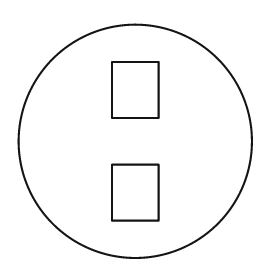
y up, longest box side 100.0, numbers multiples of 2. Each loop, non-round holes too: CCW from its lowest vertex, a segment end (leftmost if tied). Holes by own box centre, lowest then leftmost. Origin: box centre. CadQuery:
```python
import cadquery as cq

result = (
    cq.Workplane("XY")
    .moveTo(0.0, 0.0)
    .circle(50.0)
    .moveTo(-10.0, -34.0)
    .lineTo(10.0, -34.0)
    .lineTo(10.0, -10.0)
    .lineTo(-10.0, -10.0)
    .close()
    .moveTo(-10.0, 10.0)
    .lineTo(10.0, 10.0)
    .lineTo(10.0, 34.0)
    .lineTo(-10.0, 34.0)
    .close()
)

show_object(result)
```